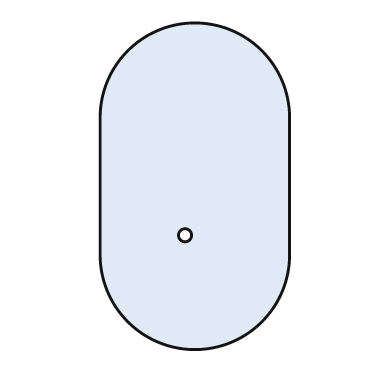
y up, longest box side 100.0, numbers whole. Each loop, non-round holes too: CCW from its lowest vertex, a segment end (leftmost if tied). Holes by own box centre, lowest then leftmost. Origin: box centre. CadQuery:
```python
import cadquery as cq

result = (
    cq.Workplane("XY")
    .moveTo(-29.0, -21.0)
    .threePointArc((0.0, -50.0), (29.0, -21.0))
    .lineTo(29.0, 21.0)
    .threePointArc((0.0, 50.0), (-29.0, 21.0))
    .close()
    .moveTo(-3.0, -15.0)
    .circle(2.0)
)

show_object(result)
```